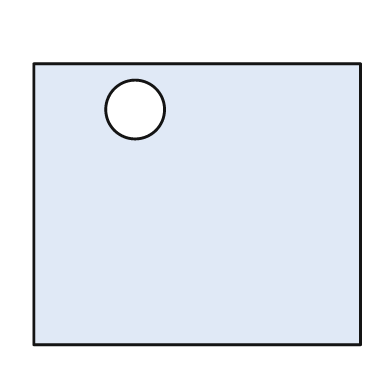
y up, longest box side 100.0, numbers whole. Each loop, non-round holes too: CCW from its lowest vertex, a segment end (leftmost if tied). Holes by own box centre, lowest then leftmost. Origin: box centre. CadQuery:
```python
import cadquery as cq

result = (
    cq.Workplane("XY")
    .moveTo(-50.0, -43.0)
    .lineTo(50.0, -43.0)
    .lineTo(50.0, 43.0)
    .lineTo(-50.0, 43.0)
    .close()
    .moveTo(-19.0, 29.0)
    .circle(9.0)
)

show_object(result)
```